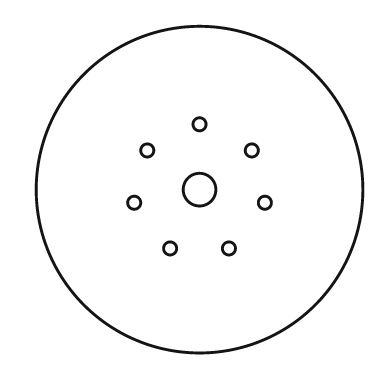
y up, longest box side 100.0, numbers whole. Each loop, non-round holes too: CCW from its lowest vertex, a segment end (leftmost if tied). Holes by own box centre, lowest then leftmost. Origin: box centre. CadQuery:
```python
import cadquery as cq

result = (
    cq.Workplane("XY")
    .moveTo(0.0, 0.0)
    .circle(50.0)
    .moveTo(-9.0, -18.0)
    .circle(2.0)
    .moveTo(9.0, -18.0)
    .circle(2.0)
    .moveTo(-20.0, -4.0)
    .circle(2.0)
    .moveTo(20.0, -4.0)
    .circle(2.0)
    .moveTo(0.0, 0.0)
    .circle(5.0)
    .moveTo(-16.0, 12.0)
    .circle(2.0)
    .moveTo(16.0, 12.0)
    .circle(2.0)
    .moveTo(0.0, 20.0)
    .circle(2.0)
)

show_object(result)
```